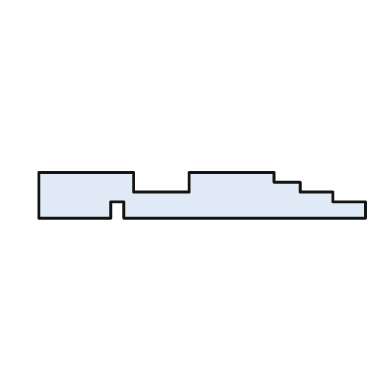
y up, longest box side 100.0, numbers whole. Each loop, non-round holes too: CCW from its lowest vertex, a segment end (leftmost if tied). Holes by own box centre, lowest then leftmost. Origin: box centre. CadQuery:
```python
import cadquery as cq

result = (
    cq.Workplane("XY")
    .moveTo(-50.0, -7.0)
    .lineTo(-28.0, -7.0)
    .lineTo(-28.0, -2.0)
    .lineTo(-24.0, -2.0)
    .lineTo(-24.0, -7.0)
    .lineTo(50.0, -7.0)
    .lineTo(50.0, -2.0)
    .lineTo(40.0, -2.0)
    .lineTo(40.0, 1.0)
    .lineTo(30.0, 1.0)
    .lineTo(30.0, 4.0)
    .lineTo(22.0, 4.0)
    .lineTo(22.0, 7.0)
    .lineTo(-4.0, 7.0)
    .lineTo(-4.0, 1.0)
    .lineTo(-21.0, 1.0)
    .lineTo(-21.0, 7.0)
    .lineTo(-50.0, 7.0)
    .close()
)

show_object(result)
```